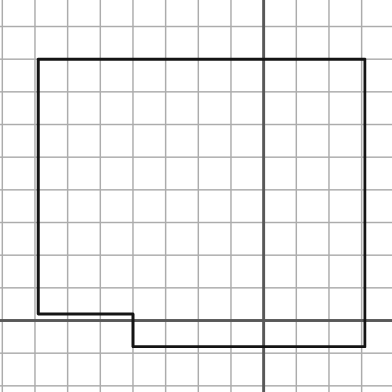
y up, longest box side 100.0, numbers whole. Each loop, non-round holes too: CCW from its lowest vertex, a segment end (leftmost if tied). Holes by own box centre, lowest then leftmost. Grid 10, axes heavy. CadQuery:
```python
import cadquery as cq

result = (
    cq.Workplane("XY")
    .moveTo(-40.0, -8.0)
    .lineTo(31.0, -8.0)
    .lineTo(31.0, 80.0)
    .lineTo(-69.0, 80.0)
    .lineTo(-69.0, 2.0)
    .lineTo(-40.0, 2.0)
    .close()
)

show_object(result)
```